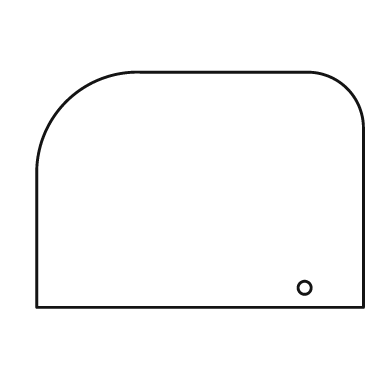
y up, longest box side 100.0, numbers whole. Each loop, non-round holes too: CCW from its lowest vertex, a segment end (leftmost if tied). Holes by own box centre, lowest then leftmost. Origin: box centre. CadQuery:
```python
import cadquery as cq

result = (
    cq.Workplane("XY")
    .moveTo(-50.0, -36.0)
    .lineTo(50.0, -36.0)
    .lineTo(50.0, 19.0)
    .threePointArc((45.0, 31.0), (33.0, 36.0))
    .lineTo(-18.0, 36.0)
    .threePointArc((-41.0, 27.0), (-50.0, 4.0))
    .close()
    .moveTo(32.0, -30.0)
    .circle(2.0)
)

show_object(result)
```